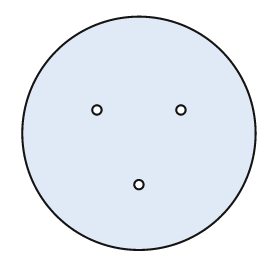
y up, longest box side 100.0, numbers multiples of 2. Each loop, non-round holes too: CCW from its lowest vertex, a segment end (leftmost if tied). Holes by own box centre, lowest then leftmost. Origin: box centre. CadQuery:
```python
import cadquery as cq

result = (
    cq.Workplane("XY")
    .moveTo(0.0, 0.0)
    .circle(50.0)
    .moveTo(0.0, -22.0)
    .circle(2.0)
    .moveTo(-18.0, 10.0)
    .circle(2.0)
    .moveTo(18.0, 10.0)
    .circle(2.0)
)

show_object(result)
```